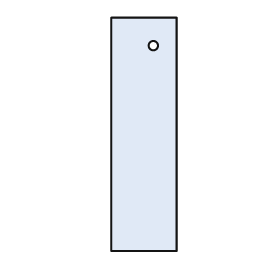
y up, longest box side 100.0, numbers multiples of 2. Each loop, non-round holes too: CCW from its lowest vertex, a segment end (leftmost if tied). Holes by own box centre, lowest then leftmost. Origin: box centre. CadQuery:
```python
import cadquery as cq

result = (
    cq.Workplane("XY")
    .moveTo(-14.0, -50.0)
    .lineTo(14.0, -50.0)
    .lineTo(14.0, 50.0)
    .lineTo(-14.0, 50.0)
    .close()
    .moveTo(4.0, 38.0)
    .circle(2.0)
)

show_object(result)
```